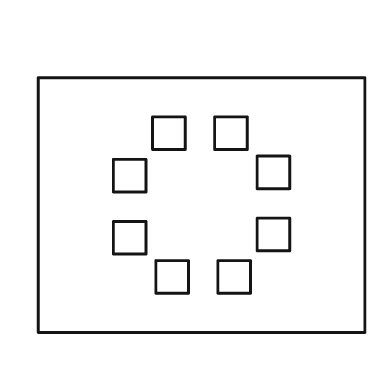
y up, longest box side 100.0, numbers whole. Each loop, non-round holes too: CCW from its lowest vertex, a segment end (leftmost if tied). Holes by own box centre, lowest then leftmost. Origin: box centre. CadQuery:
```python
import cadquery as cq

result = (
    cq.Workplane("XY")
    .moveTo(-50.0, -39.0)
    .lineTo(50.0, -39.0)
    .lineTo(50.0, 39.0)
    .lineTo(-50.0, 39.0)
    .close()
    .moveTo(-14.0, -27.0)
    .lineTo(-4.0, -27.0)
    .lineTo(-4.0, -17.0)
    .lineTo(-14.0, -17.0)
    .close()
    .moveTo(5.0, -27.0)
    .lineTo(15.0, -27.0)
    .lineTo(15.0, -17.0)
    .lineTo(5.0, -17.0)
    .close()
    .moveTo(-27.0, -15.0)
    .lineTo(-17.0, -15.0)
    .lineTo(-17.0, -5.0)
    .lineTo(-27.0, -5.0)
    .close()
    .moveTo(17.0, -14.0)
    .lineTo(27.0, -14.0)
    .lineTo(27.0, -4.0)
    .lineTo(17.0, -4.0)
    .close()
    .moveTo(-27.0, 4.0)
    .lineTo(-17.0, 4.0)
    .lineTo(-17.0, 14.0)
    .lineTo(-27.0, 14.0)
    .close()
    .moveTo(17.0, 5.0)
    .lineTo(27.0, 5.0)
    .lineTo(27.0, 15.0)
    .lineTo(17.0, 15.0)
    .close()
    .moveTo(-15.0, 17.0)
    .lineTo(-5.0, 17.0)
    .lineTo(-5.0, 27.0)
    .lineTo(-15.0, 27.0)
    .close()
    .moveTo(4.0, 17.0)
    .lineTo(14.0, 17.0)
    .lineTo(14.0, 27.0)
    .lineTo(4.0, 27.0)
    .close()
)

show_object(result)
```